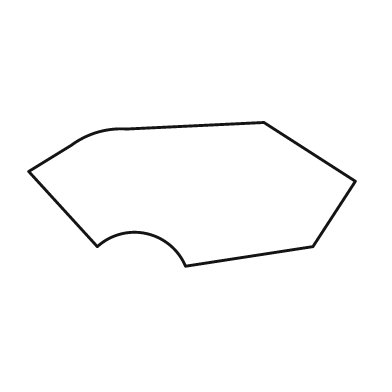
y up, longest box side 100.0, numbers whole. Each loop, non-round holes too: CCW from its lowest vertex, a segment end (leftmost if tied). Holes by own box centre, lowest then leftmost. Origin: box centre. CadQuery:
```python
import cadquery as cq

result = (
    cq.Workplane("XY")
    .moveTo(-2.0, -22.0)
    .lineTo(37.0, -16.0)
    .lineTo(50.0, 4.0)
    .lineTo(22.0, 22.0)
    .lineTo(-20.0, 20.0)
    .threePointArc((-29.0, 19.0), (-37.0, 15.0))
    .lineTo(-50.0, 7.0)
    .lineTo(-29.0, -16.0)
    .threePointArc((-14.0, -12.0), (-2.0, -22.0))
    .close()
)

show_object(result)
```